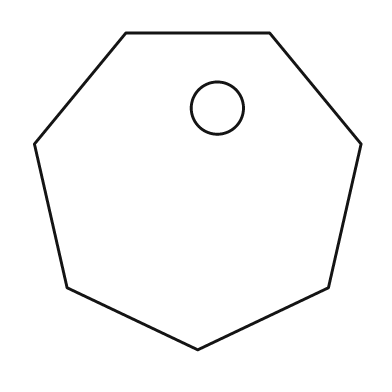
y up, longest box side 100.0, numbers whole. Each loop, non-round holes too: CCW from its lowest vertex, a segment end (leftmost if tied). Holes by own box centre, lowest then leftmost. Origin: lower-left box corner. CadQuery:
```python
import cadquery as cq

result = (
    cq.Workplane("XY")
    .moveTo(50.0, 0.0)
    .lineTo(90.0, 19.0)
    .lineTo(100.0, 63.0)
    .lineTo(72.0, 97.0)
    .lineTo(28.0, 97.0)
    .lineTo(0.0, 63.0)
    .lineTo(10.0, 19.0)
    .close()
    .moveTo(56.0, 74.0)
    .circle(8.0)
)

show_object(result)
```